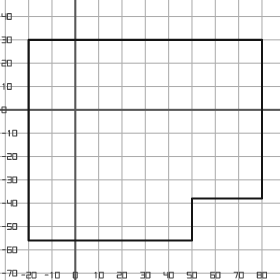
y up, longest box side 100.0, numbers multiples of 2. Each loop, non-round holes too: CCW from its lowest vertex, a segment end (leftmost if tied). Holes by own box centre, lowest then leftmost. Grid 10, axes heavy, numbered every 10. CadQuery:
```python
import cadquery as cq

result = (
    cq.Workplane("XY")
    .moveTo(-20.0, -56.0)
    .lineTo(50.0, -56.0)
    .lineTo(50.0, -38.0)
    .lineTo(80.0, -38.0)
    .lineTo(80.0, 30.0)
    .lineTo(-20.0, 30.0)
    .close()
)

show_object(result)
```